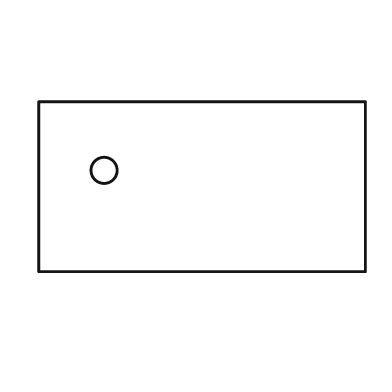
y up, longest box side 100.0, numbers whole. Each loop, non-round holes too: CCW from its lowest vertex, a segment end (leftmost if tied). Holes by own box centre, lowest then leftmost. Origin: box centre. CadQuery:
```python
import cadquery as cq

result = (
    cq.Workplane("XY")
    .moveTo(-50.0, -26.0)
    .lineTo(50.0, -26.0)
    .lineTo(50.0, 26.0)
    .lineTo(-50.0, 26.0)
    .close()
    .moveTo(-30.0, 5.0)
    .circle(4.0)
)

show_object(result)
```